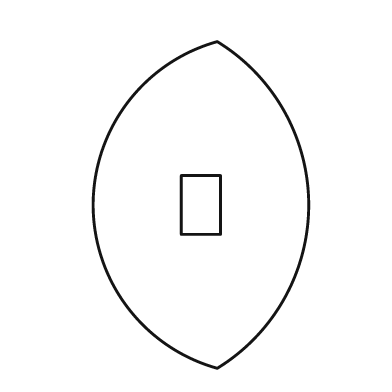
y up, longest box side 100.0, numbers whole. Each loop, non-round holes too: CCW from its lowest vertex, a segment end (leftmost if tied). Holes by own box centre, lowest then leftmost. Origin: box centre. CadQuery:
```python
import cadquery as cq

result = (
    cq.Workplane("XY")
    .moveTo(5.0, -50.0)
    .threePointArc((33.0, 0.0), (5.0, 50.0))
    .threePointArc((-33.0, 0.0), (5.0, -50.0))
    .close()
    .moveTo(-6.0, -9.0)
    .lineTo(6.0, -9.0)
    .lineTo(6.0, 9.0)
    .lineTo(-6.0, 9.0)
    .close()
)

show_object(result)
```